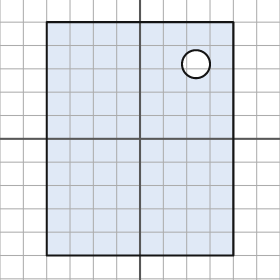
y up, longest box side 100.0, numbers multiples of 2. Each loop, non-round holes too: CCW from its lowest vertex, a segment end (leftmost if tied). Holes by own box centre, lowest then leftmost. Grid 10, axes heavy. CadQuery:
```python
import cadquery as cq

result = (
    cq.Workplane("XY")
    .moveTo(-40.0, -50.0)
    .lineTo(40.0, -50.0)
    .lineTo(40.0, 50.0)
    .lineTo(-40.0, 50.0)
    .close()
    .moveTo(24.0, 32.0)
    .circle(6.0)
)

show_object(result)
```